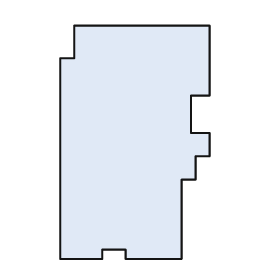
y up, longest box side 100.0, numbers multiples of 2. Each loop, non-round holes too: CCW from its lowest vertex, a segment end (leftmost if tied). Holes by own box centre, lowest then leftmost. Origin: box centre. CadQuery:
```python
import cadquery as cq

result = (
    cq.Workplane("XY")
    .moveTo(-32.0, -50.0)
    .lineTo(-14.0, -50.0)
    .lineTo(-14.0, -46.0)
    .lineTo(-4.0, -46.0)
    .lineTo(-4.0, -50.0)
    .lineTo(20.0, -50.0)
    .lineTo(20.0, -16.0)
    .lineTo(26.0, -16.0)
    .lineTo(26.0, -6.0)
    .lineTo(32.0, -6.0)
    .lineTo(32.0, 4.0)
    .lineTo(24.0, 4.0)
    .lineTo(24.0, 20.0)
    .lineTo(32.0, 20.0)
    .lineTo(32.0, 50.0)
    .lineTo(-26.0, 50.0)
    .lineTo(-26.0, 36.0)
    .lineTo(-32.0, 36.0)
    .close()
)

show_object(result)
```